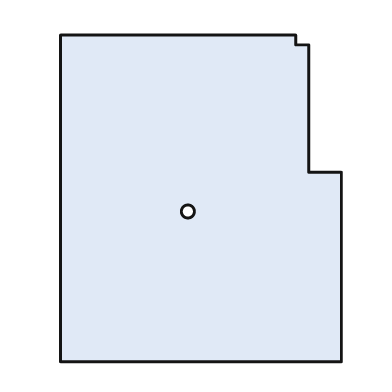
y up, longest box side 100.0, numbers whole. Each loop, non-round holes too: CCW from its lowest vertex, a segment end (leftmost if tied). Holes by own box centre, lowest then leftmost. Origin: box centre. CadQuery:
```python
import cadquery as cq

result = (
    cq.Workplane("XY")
    .moveTo(-43.0, -50.0)
    .lineTo(43.0, -50.0)
    .lineTo(43.0, 8.0)
    .lineTo(33.0, 8.0)
    .lineTo(33.0, 47.0)
    .lineTo(29.0, 47.0)
    .lineTo(29.0, 50.0)
    .lineTo(-43.0, 50.0)
    .close()
    .moveTo(-4.0, -4.0)
    .circle(2.0)
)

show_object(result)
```